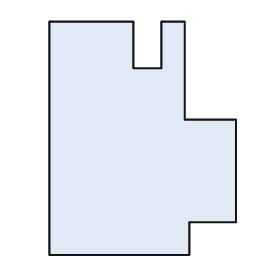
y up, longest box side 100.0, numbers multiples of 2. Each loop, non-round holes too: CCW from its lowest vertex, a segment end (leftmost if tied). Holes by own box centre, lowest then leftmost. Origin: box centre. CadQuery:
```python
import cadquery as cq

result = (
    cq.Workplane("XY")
    .moveTo(-40.0, -50.0)
    .lineTo(20.0, -50.0)
    .lineTo(20.0, -36.0)
    .lineTo(40.0, -36.0)
    .lineTo(40.0, 8.0)
    .lineTo(18.0, 8.0)
    .lineTo(18.0, 50.0)
    .lineTo(8.0, 50.0)
    .lineTo(8.0, 30.0)
    .lineTo(-4.0, 30.0)
    .lineTo(-4.0, 50.0)
    .lineTo(-40.0, 50.0)
    .close()
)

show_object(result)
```